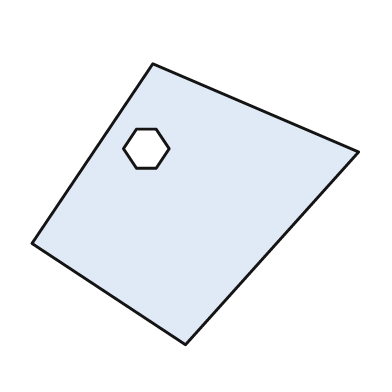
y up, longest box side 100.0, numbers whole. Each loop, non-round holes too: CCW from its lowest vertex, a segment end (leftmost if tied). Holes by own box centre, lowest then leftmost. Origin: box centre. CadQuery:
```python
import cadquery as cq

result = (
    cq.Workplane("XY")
    .moveTo(-3.0, -43.0)
    .lineTo(50.0, 16.0)
    .lineTo(-13.0, 43.0)
    .lineTo(-50.0, -12.0)
    .close()
    .moveTo(-18.0, 11.0)
    .lineTo(-12.0, 11.0)
    .lineTo(-8.0, 17.0)
    .lineTo(-12.0, 23.0)
    .lineTo(-18.0, 23.0)
    .lineTo(-22.0, 17.0)
    .close()
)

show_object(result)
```